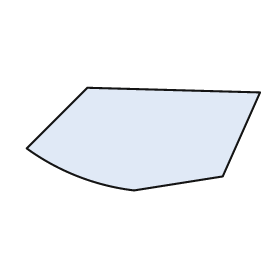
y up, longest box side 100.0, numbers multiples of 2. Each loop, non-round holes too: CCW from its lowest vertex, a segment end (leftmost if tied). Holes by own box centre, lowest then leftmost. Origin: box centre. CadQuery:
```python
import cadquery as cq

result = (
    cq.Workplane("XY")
    .moveTo(-4.0, -22.0)
    .lineTo(34.0, -16.0)
    .lineTo(50.0, 20.0)
    .lineTo(-24.0, 22.0)
    .lineTo(-50.0, -4.0)
    .threePointArc((-28.0, -16.0), (-4.0, -22.0))
    .close()
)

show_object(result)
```